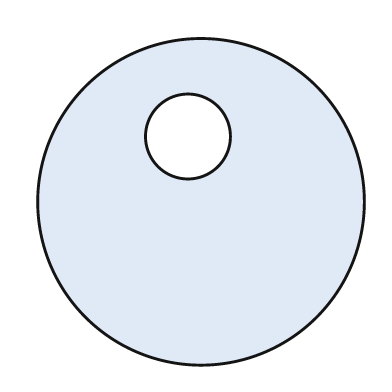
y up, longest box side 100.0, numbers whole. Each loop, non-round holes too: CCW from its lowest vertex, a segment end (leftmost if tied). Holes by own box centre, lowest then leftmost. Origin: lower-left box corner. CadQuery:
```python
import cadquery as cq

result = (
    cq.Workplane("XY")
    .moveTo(50.0, 50.0)
    .circle(50.0)
    .moveTo(46.0, 70.0)
    .circle(13.0)
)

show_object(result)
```